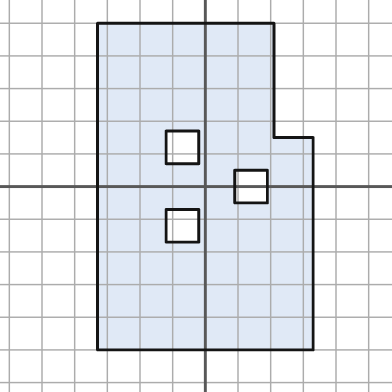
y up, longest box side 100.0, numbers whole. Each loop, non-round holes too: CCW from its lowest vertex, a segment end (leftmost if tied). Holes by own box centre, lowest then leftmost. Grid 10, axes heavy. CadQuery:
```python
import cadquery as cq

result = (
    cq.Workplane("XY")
    .moveTo(-33.0, -50.0)
    .lineTo(33.0, -50.0)
    .lineTo(33.0, 15.0)
    .lineTo(21.0, 15.0)
    .lineTo(21.0, 50.0)
    .lineTo(-33.0, 50.0)
    .close()
    .moveTo(-12.0, -17.0)
    .lineTo(-2.0, -17.0)
    .lineTo(-2.0, -7.0)
    .lineTo(-12.0, -7.0)
    .close()
    .moveTo(9.0, -5.0)
    .lineTo(19.0, -5.0)
    .lineTo(19.0, 5.0)
    .lineTo(9.0, 5.0)
    .close()
    .moveTo(-12.0, 7.0)
    .lineTo(-2.0, 7.0)
    .lineTo(-2.0, 17.0)
    .lineTo(-12.0, 17.0)
    .close()
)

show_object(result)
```